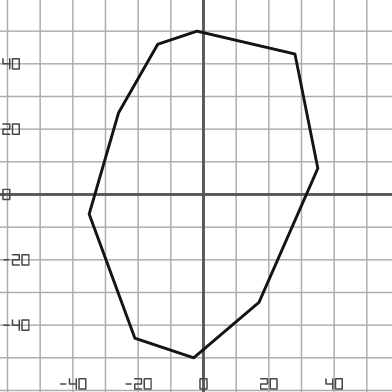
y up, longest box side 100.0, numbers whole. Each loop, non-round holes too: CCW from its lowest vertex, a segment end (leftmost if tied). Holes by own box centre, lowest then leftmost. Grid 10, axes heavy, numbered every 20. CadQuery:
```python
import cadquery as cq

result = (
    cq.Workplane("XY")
    .moveTo(-3.0, -50.0)
    .lineTo(17.0, -33.0)
    .lineTo(35.0, 8.0)
    .lineTo(28.0, 43.0)
    .lineTo(-2.0, 50.0)
    .lineTo(-14.0, 46.0)
    .lineTo(-26.0, 25.0)
    .lineTo(-35.0, -6.0)
    .lineTo(-21.0, -44.0)
    .close()
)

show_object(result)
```